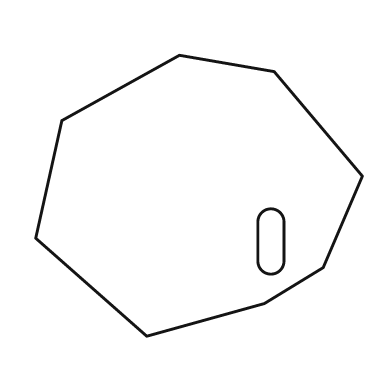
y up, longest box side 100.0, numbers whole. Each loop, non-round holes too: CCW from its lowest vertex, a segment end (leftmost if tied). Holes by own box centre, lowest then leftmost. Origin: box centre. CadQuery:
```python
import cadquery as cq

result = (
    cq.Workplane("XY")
    .moveTo(-16.0, -43.0)
    .lineTo(20.0, -33.0)
    .lineTo(38.0, -22.0)
    .lineTo(50.0, 6.0)
    .lineTo(23.0, 38.0)
    .lineTo(-6.0, 43.0)
    .lineTo(-42.0, 23.0)
    .lineTo(-50.0, -13.0)
    .close()
    .moveTo(18.0, -20.0)
    .threePointArc((22.0, -24.0), (26.0, -20.0))
    .lineTo(26.0, -8.0)
    .threePointArc((22.0, -4.0), (18.0, -8.0))
    .close()
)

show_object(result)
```